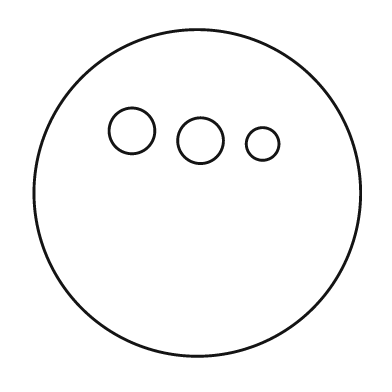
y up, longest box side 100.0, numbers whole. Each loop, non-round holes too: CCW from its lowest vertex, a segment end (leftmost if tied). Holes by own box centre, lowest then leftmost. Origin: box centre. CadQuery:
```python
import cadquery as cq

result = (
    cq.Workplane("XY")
    .moveTo(0.0, 0.0)
    .circle(50.0)
    .moveTo(20.0, 15.0)
    .circle(5.0)
    .moveTo(1.0, 16.0)
    .circle(7.0)
    .moveTo(-20.0, 19.0)
    .circle(7.0)
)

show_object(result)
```